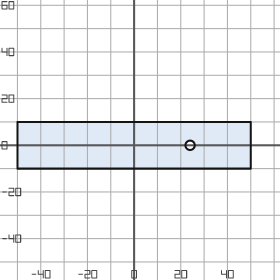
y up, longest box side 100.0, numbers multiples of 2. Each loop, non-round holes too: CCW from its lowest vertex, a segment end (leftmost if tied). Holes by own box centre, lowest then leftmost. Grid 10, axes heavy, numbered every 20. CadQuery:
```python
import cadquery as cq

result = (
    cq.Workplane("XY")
    .moveTo(-50.0, -10.0)
    .lineTo(50.0, -10.0)
    .lineTo(50.0, 10.0)
    .lineTo(-50.0, 10.0)
    .close()
    .moveTo(24.0, 0.0)
    .circle(2.0)
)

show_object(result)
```